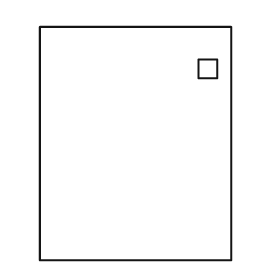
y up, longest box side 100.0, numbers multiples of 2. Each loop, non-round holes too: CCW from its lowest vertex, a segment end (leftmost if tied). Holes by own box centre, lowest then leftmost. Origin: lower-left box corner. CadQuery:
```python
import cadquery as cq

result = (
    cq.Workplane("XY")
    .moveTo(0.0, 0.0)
    .lineTo(82.0, 0.0)
    .lineTo(82.0, 100.0)
    .lineTo(0.0, 100.0)
    .close()
    .moveTo(68.0, 78.0)
    .lineTo(76.0, 78.0)
    .lineTo(76.0, 86.0)
    .lineTo(68.0, 86.0)
    .close()
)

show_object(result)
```